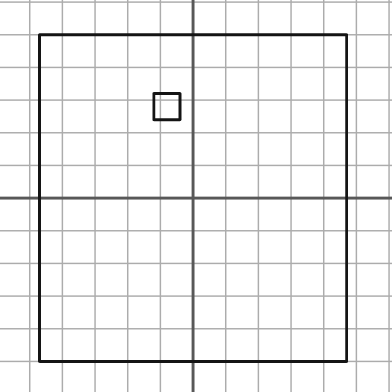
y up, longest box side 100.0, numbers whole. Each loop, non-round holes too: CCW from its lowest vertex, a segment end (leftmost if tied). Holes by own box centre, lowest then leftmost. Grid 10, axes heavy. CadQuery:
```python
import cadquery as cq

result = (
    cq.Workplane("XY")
    .moveTo(-47.0, -50.0)
    .lineTo(47.0, -50.0)
    .lineTo(47.0, 50.0)
    .lineTo(-47.0, 50.0)
    .close()
    .moveTo(-12.0, 24.0)
    .lineTo(-4.0, 24.0)
    .lineTo(-4.0, 32.0)
    .lineTo(-12.0, 32.0)
    .close()
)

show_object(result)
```